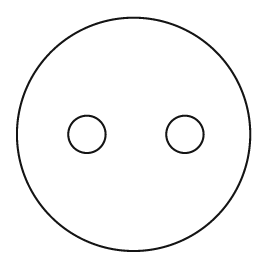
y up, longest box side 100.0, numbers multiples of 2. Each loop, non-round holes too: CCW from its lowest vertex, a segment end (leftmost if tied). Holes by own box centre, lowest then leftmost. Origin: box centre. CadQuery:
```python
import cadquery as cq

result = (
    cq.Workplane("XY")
    .moveTo(0.0, 0.0)
    .circle(50.0)
    .moveTo(-20.0, 0.0)
    .circle(8.0)
    .moveTo(22.0, 0.0)
    .circle(8.0)
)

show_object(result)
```